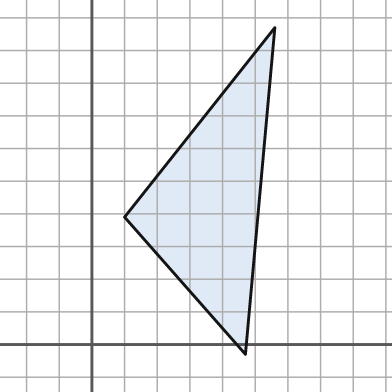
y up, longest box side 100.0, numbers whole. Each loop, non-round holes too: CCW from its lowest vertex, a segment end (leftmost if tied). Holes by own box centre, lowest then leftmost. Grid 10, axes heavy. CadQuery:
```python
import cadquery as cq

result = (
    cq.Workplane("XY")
    .moveTo(47.0, -3.0)
    .lineTo(56.0, 97.0)
    .lineTo(10.0, 39.0)
    .close()
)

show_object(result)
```